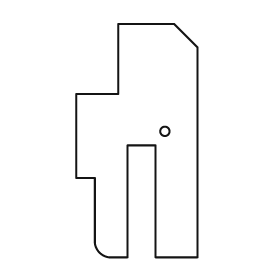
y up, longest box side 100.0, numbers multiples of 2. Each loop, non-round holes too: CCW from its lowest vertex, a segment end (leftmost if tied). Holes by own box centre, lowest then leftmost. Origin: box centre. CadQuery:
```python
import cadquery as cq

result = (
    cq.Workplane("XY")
    .moveTo(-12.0, -50.0)
    .lineTo(-4.0, -50.0)
    .lineTo(-4.0, -2.0)
    .lineTo(8.0, -2.0)
    .lineTo(8.0, -50.0)
    .lineTo(26.0, -50.0)
    .lineTo(26.0, 40.0)
    .lineTo(16.0, 50.0)
    .lineTo(-8.0, 50.0)
    .lineTo(-8.0, 20.0)
    .lineTo(-26.0, 20.0)
    .lineTo(-26.0, -16.0)
    .lineTo(-18.0, -16.0)
    .lineTo(-18.0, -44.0)
    .threePointArc((-16.0, -48.0), (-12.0, -50.0))
    .close()
    .moveTo(12.0, 4.0)
    .circle(2.0)
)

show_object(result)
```